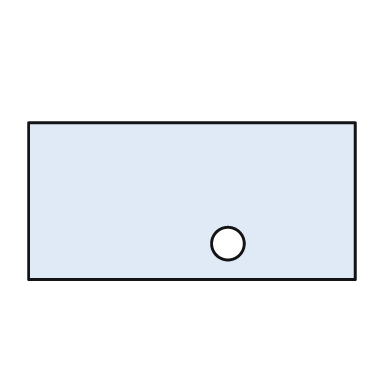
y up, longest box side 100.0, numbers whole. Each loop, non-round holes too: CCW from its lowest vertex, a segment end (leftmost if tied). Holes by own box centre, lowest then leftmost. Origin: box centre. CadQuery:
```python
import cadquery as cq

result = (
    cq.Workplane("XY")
    .moveTo(-50.0, -24.0)
    .lineTo(50.0, -24.0)
    .lineTo(50.0, 24.0)
    .lineTo(-50.0, 24.0)
    .close()
    .moveTo(11.0, -13.0)
    .circle(5.0)
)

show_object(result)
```